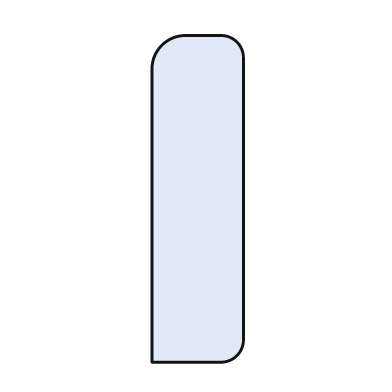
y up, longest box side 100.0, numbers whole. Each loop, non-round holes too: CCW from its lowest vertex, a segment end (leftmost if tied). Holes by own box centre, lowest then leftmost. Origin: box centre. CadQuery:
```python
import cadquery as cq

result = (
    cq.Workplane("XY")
    .moveTo(-14.0, -50.0)
    .lineTo(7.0, -50.0)
    .threePointArc((12.0, -48.0), (14.0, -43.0))
    .lineTo(14.0, 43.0)
    .threePointArc((12.0, 48.0), (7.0, 50.0))
    .lineTo(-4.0, 50.0)
    .threePointArc((-11.0, 47.0), (-14.0, 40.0))
    .close()
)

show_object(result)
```